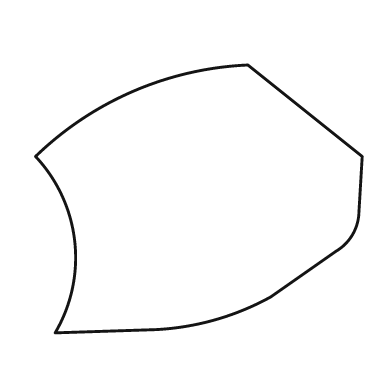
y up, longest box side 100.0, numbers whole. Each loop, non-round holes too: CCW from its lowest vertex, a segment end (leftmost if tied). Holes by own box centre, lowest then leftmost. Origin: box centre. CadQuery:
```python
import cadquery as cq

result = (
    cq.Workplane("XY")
    .moveTo(-44.0, -41.0)
    .lineTo(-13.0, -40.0)
    .threePointArc((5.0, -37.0), (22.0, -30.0))
    .lineTo(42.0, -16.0)
    .threePointArc((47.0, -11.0), (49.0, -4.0))
    .lineTo(50.0, 13.0)
    .lineTo(15.0, 41.0)
    .threePointArc((-20.0, 33.0), (-50.0, 13.0))
    .threePointArc((-38.0, -13.0), (-44.0, -41.0))
    .close()
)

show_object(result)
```